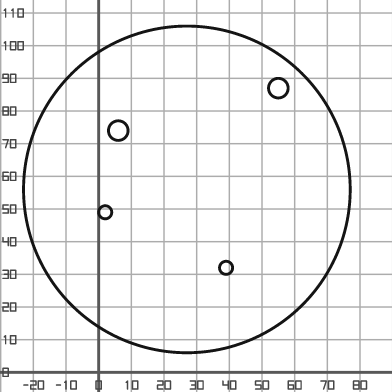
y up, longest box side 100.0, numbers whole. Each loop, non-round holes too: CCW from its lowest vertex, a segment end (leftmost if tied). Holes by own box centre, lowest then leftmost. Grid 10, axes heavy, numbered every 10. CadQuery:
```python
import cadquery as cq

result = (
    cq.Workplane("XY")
    .moveTo(27.0, 56.0)
    .circle(50.0)
    .moveTo(39.0, 32.0)
    .circle(2.0)
    .moveTo(2.0, 49.0)
    .circle(2.0)
    .moveTo(6.0, 74.0)
    .circle(3.0)
    .moveTo(55.0, 87.0)
    .circle(3.0)
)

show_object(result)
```